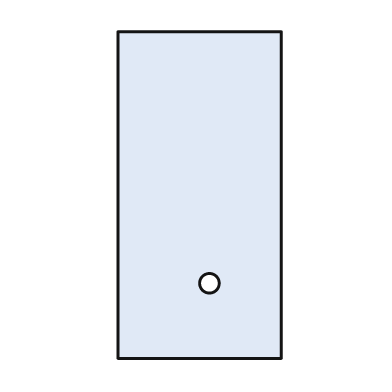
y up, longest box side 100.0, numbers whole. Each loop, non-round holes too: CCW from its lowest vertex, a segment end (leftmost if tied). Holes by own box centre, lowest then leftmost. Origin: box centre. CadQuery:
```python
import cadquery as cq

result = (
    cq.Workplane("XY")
    .moveTo(-25.0, -50.0)
    .lineTo(25.0, -50.0)
    .lineTo(25.0, 50.0)
    .lineTo(-25.0, 50.0)
    .close()
    .moveTo(3.0, -27.0)
    .circle(3.0)
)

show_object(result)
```